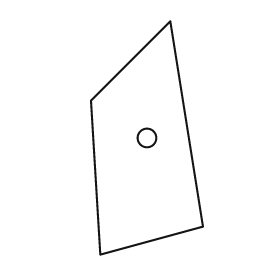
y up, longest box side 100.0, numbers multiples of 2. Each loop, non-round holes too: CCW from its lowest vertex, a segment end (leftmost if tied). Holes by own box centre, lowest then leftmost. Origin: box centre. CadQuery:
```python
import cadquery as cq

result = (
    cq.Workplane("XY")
    .moveTo(-20.0, -50.0)
    .lineTo(24.0, -38.0)
    .lineTo(10.0, 50.0)
    .lineTo(-24.0, 16.0)
    .close()
    .moveTo(0.0, 0.0)
    .circle(4.0)
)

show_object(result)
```